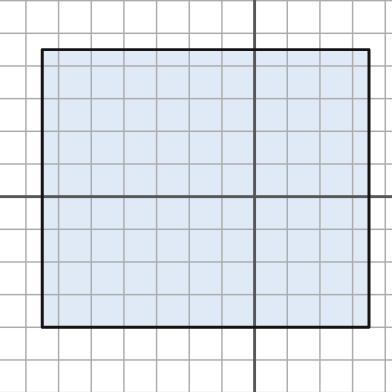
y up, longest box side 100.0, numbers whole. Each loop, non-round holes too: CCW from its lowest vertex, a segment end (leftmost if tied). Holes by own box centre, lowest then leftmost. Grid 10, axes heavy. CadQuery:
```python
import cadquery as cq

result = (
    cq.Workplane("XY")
    .moveTo(-65.0, -40.0)
    .lineTo(35.0, -40.0)
    .lineTo(35.0, 45.0)
    .lineTo(-65.0, 45.0)
    .close()
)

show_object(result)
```